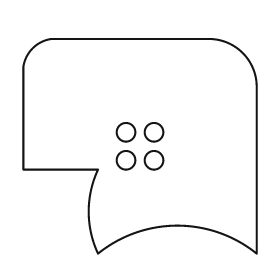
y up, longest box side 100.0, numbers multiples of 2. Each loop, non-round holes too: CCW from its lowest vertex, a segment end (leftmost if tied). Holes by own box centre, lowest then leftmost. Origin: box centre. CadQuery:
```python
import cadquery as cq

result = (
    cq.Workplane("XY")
    .moveTo(-18.0, -46.0)
    .threePointArc((16.0, -34.0), (50.0, -46.0))
    .lineTo(50.0, 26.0)
    .threePointArc((44.0, 40.0), (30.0, 46.0))
    .lineTo(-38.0, 46.0)
    .threePointArc((-46.0, 42.0), (-50.0, 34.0))
    .lineTo(-50.0, -10.0)
    .lineTo(-18.0, -10.0)
    .threePointArc((-22.0, -28.0), (-18.0, -46.0))
    .close()
    .moveTo(-6.0, -6.0)
    .circle(4.0)
    .moveTo(6.0, -6.0)
    .circle(4.0)
    .moveTo(-6.0, 6.0)
    .circle(4.0)
    .moveTo(6.0, 6.0)
    .circle(4.0)
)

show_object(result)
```